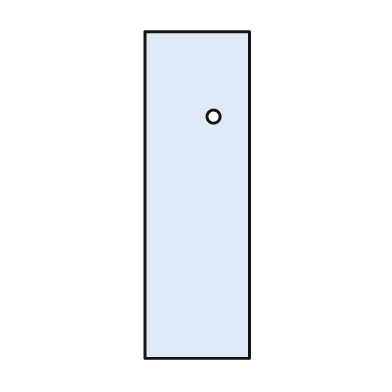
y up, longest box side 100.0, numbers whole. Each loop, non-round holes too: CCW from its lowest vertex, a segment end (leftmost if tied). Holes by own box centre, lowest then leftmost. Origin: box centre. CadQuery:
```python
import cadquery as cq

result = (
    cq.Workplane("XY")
    .moveTo(-16.0, -50.0)
    .lineTo(16.0, -50.0)
    .lineTo(16.0, 50.0)
    .lineTo(-16.0, 50.0)
    .close()
    .moveTo(5.0, 24.0)
    .circle(2.0)
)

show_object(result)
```